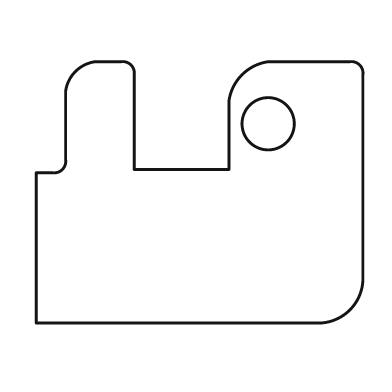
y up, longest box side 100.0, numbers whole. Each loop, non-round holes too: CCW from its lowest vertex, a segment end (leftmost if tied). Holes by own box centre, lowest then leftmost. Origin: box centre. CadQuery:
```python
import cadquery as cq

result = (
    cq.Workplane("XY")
    .moveTo(-50.0, -40.0)
    .lineTo(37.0, -40.0)
    .threePointArc((46.0, -36.0), (50.0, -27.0))
    .lineTo(50.0, 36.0)
    .threePointArc((49.0, 39.0), (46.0, 40.0))
    .lineTo(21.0, 40.0)
    .threePointArc((13.0, 36.0), (9.0, 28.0))
    .lineTo(9.0, 7.0)
    .lineTo(-20.0, 7.0)
    .lineTo(-20.0, 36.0)
    .threePointArc((-21.0, 39.0), (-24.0, 40.0))
    .lineTo(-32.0, 40.0)
    .threePointArc((-38.0, 37.0), (-41.0, 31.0))
    .lineTo(-41.0, 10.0)
    .threePointArc((-42.0, 7.0), (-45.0, 6.0))
    .lineTo(-50.0, 6.0)
    .close()
    .moveTo(21.0, 21.0)
    .circle(8.0)
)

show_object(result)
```